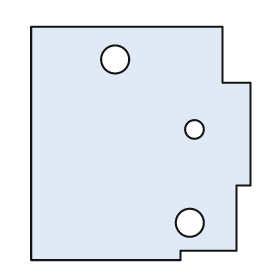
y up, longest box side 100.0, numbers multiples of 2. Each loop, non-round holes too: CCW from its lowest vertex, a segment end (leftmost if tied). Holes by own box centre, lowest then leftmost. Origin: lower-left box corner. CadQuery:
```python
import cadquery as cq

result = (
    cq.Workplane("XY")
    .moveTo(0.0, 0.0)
    .lineTo(64.0, 0.0)
    .lineTo(64.0, 4.0)
    .lineTo(88.0, 4.0)
    .lineTo(88.0, 32.0)
    .lineTo(94.0, 32.0)
    .lineTo(94.0, 76.0)
    .lineTo(82.0, 76.0)
    .lineTo(82.0, 100.0)
    .lineTo(0.0, 100.0)
    .close()
    .moveTo(68.0, 16.0)
    .circle(6.0)
    .moveTo(70.0, 56.0)
    .circle(4.0)
    .moveTo(36.0, 86.0)
    .circle(6.0)
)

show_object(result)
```